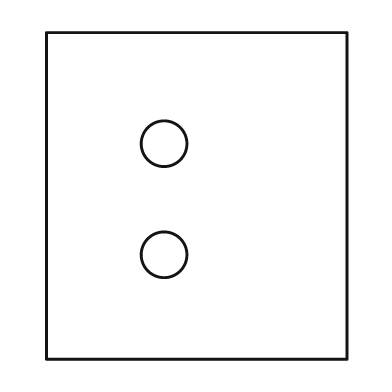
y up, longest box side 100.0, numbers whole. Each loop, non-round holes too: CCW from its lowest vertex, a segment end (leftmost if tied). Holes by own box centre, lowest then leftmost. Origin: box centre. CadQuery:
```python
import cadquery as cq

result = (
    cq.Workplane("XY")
    .moveTo(-46.0, -50.0)
    .lineTo(46.0, -50.0)
    .lineTo(46.0, 50.0)
    .lineTo(-46.0, 50.0)
    .close()
    .moveTo(-10.0, -18.0)
    .circle(7.0)
    .moveTo(-10.0, 16.0)
    .circle(7.0)
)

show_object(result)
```